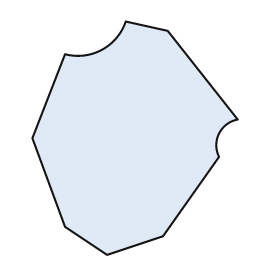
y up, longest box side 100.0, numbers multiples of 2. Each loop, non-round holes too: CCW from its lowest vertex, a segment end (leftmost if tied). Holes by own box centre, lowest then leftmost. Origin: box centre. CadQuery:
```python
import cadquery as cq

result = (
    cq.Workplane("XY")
    .moveTo(-12.0, -50.0)
    .lineTo(12.0, -42.0)
    .lineTo(36.0, -8.0)
    .threePointArc((36.0, 2.0), (44.0, 8.0))
    .lineTo(14.0, 46.0)
    .lineTo(-4.0, 50.0)
    .threePointArc((-14.0, 38.0), (-30.0, 36.0))
    .lineTo(-44.0, 0.0)
    .lineTo(-30.0, -38.0)
    .close()
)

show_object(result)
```